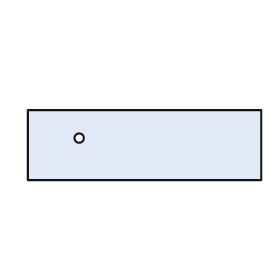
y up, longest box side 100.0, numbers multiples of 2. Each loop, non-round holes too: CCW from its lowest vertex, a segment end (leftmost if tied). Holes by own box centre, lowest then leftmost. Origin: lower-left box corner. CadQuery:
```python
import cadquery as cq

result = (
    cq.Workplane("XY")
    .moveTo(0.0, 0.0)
    .lineTo(100.0, 0.0)
    .lineTo(100.0, 30.0)
    .lineTo(0.0, 30.0)
    .close()
    .moveTo(22.0, 18.0)
    .circle(2.0)
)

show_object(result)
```